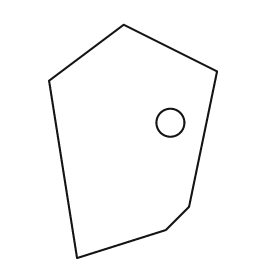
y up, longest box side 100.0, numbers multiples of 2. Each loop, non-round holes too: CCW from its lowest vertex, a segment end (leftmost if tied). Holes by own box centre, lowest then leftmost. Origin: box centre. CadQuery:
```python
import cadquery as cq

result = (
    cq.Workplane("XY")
    .moveTo(-24.0, -50.0)
    .lineTo(14.0, -38.0)
    .lineTo(24.0, -28.0)
    .lineTo(36.0, 30.0)
    .lineTo(-4.0, 50.0)
    .lineTo(-36.0, 26.0)
    .close()
    .moveTo(16.0, 8.0)
    .circle(6.0)
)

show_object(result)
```